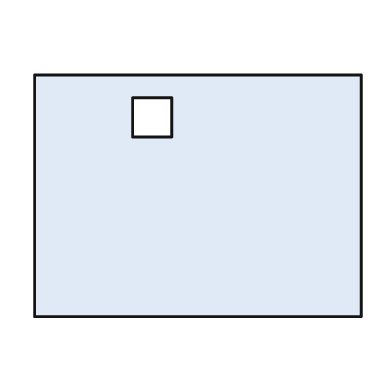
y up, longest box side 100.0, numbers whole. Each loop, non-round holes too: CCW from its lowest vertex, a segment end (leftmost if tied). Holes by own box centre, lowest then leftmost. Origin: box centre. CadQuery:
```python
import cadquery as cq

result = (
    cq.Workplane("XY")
    .moveTo(-50.0, -37.0)
    .lineTo(50.0, -37.0)
    .lineTo(50.0, 37.0)
    .lineTo(-50.0, 37.0)
    .close()
    .moveTo(-20.0, 18.0)
    .lineTo(-8.0, 18.0)
    .lineTo(-8.0, 30.0)
    .lineTo(-20.0, 30.0)
    .close()
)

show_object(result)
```